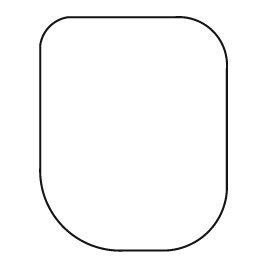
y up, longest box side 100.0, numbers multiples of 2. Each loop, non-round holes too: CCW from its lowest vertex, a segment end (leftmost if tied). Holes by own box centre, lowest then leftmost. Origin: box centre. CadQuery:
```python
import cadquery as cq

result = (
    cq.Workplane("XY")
    .moveTo(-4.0, -50.0)
    .lineTo(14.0, -50.0)
    .threePointArc((32.0, -42.0), (40.0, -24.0))
    .lineTo(40.0, 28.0)
    .threePointArc((34.0, 44.0), (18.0, 50.0))
    .lineTo(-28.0, 50.0)
    .threePointArc((-36.0, 46.0), (-40.0, 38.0))
    .lineTo(-40.0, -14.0)
    .threePointArc((-30.0, -40.0), (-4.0, -50.0))
    .close()
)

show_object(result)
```